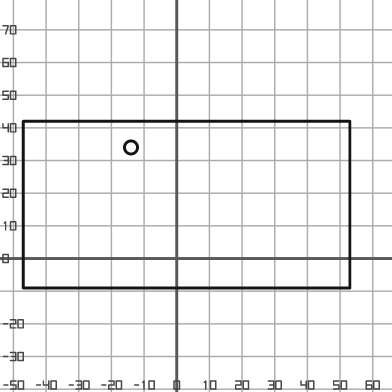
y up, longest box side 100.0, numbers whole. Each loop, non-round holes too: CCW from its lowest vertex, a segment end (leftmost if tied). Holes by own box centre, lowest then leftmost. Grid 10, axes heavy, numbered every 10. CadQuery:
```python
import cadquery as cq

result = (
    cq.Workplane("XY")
    .moveTo(-47.0, -9.0)
    .lineTo(53.0, -9.0)
    .lineTo(53.0, 42.0)
    .lineTo(-47.0, 42.0)
    .close()
    .moveTo(-14.0, 34.0)
    .circle(2.0)
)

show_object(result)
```